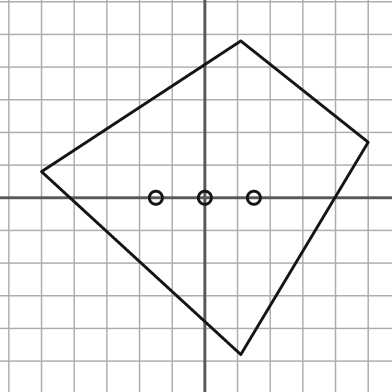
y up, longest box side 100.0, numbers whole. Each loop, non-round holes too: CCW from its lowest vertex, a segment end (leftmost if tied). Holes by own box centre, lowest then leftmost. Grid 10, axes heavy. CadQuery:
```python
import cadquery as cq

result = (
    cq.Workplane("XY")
    .moveTo(11.0, -48.0)
    .lineTo(50.0, 17.0)
    .lineTo(11.0, 48.0)
    .lineTo(-50.0, 8.0)
    .close()
    .moveTo(-15.0, 0.0)
    .circle(2.0)
    .moveTo(0.0, 0.0)
    .circle(2.0)
    .moveTo(15.0, 0.0)
    .circle(2.0)
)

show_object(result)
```